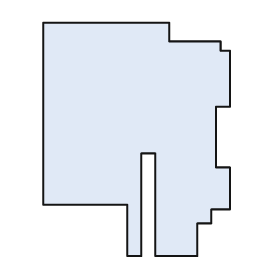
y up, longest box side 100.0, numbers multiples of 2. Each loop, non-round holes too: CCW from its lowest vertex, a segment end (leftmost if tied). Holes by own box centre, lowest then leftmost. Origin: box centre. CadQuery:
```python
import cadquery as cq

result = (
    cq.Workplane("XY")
    .moveTo(-4.0, -50.0)
    .lineTo(2.0, -50.0)
    .lineTo(2.0, -6.0)
    .lineTo(8.0, -6.0)
    .lineTo(8.0, -50.0)
    .lineTo(26.0, -50.0)
    .lineTo(26.0, -36.0)
    .lineTo(32.0, -36.0)
    .lineTo(32.0, -30.0)
    .lineTo(40.0, -30.0)
    .lineTo(40.0, -12.0)
    .lineTo(34.0, -12.0)
    .lineTo(34.0, 14.0)
    .lineTo(40.0, 14.0)
    .lineTo(40.0, 38.0)
    .lineTo(36.0, 38.0)
    .lineTo(36.0, 42.0)
    .lineTo(14.0, 42.0)
    .lineTo(14.0, 50.0)
    .lineTo(-40.0, 50.0)
    .lineTo(-40.0, -28.0)
    .lineTo(-4.0, -28.0)
    .close()
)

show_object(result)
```